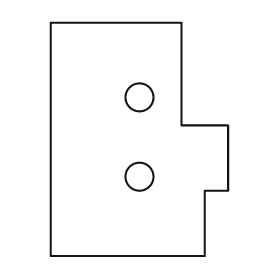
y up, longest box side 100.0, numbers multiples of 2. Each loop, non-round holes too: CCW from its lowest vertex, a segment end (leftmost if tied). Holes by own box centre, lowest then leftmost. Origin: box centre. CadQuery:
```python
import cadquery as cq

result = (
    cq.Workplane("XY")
    .moveTo(-38.0, -50.0)
    .lineTo(28.0, -50.0)
    .lineTo(28.0, -22.0)
    .lineTo(38.0, -22.0)
    .lineTo(38.0, 6.0)
    .lineTo(18.0, 6.0)
    .lineTo(18.0, 50.0)
    .lineTo(-38.0, 50.0)
    .close()
    .moveTo(0.0, -16.0)
    .circle(6.0)
    .moveTo(0.0, 18.0)
    .circle(6.0)
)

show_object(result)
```